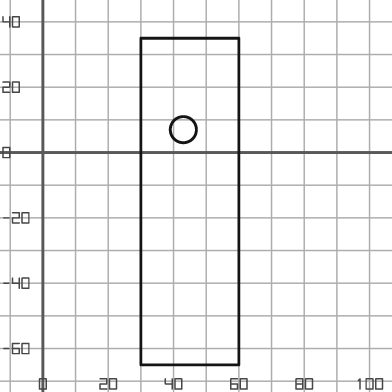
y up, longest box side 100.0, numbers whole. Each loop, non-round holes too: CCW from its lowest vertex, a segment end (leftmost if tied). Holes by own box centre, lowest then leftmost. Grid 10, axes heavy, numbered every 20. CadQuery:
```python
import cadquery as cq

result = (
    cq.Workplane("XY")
    .moveTo(30.0, -65.0)
    .lineTo(60.0, -65.0)
    .lineTo(60.0, 35.0)
    .lineTo(30.0, 35.0)
    .close()
    .moveTo(43.0, 7.0)
    .circle(4.0)
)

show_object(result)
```